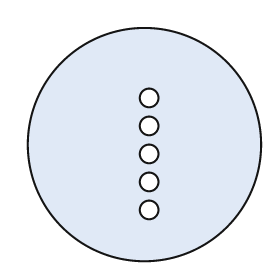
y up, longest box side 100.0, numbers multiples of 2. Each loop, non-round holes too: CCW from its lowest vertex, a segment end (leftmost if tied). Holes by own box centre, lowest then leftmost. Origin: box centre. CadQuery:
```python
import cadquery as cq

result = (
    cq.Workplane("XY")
    .moveTo(0.0, 0.0)
    .circle(50.0)
    .moveTo(2.0, -28.0)
    .circle(4.0)
    .moveTo(2.0, -16.0)
    .circle(4.0)
    .moveTo(2.0, -4.0)
    .circle(4.0)
    .moveTo(2.0, 8.0)
    .circle(4.0)
    .moveTo(2.0, 20.0)
    .circle(4.0)
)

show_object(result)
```